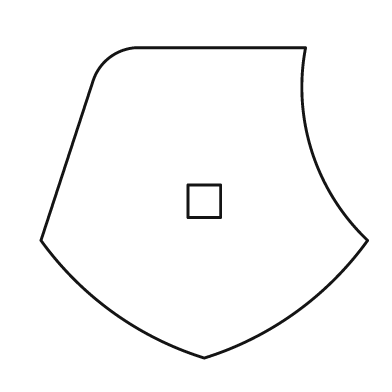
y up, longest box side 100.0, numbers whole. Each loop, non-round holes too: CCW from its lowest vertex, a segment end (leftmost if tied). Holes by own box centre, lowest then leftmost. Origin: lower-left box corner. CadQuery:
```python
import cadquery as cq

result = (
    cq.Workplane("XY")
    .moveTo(50.0, 0.0)
    .threePointArc((78.0, 14.0), (100.0, 36.0))
    .threePointArc((83.0, 63.0), (81.0, 95.0))
    .lineTo(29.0, 95.0)
    .threePointArc((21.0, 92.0), (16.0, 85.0))
    .lineTo(0.0, 36.0)
    .threePointArc((22.0, 14.0), (50.0, 0.0))
    .close()
    .moveTo(45.0, 43.0)
    .lineTo(55.0, 43.0)
    .lineTo(55.0, 53.0)
    .lineTo(45.0, 53.0)
    .close()
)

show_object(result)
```